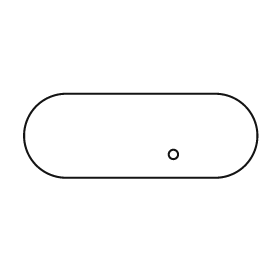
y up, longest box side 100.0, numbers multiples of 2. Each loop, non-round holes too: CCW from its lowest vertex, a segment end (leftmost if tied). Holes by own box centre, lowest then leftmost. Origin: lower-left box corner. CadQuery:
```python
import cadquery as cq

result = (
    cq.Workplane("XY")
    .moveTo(18.0, 0.0)
    .lineTo(82.0, 0.0)
    .threePointArc((100.0, 18.0), (82.0, 36.0))
    .lineTo(18.0, 36.0)
    .threePointArc((0.0, 18.0), (18.0, 0.0))
    .close()
    .moveTo(64.0, 10.0)
    .circle(2.0)
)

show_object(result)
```